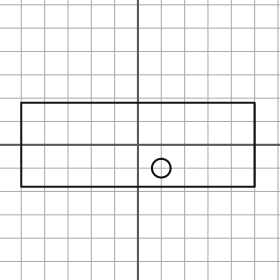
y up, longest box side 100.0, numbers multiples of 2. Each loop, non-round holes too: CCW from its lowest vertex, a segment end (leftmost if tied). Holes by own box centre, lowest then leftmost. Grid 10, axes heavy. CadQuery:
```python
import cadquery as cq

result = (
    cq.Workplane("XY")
    .moveTo(-50.0, -18.0)
    .lineTo(50.0, -18.0)
    .lineTo(50.0, 18.0)
    .lineTo(-50.0, 18.0)
    .close()
    .moveTo(10.0, -10.0)
    .circle(4.0)
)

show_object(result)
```